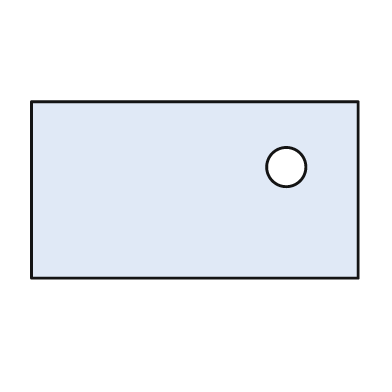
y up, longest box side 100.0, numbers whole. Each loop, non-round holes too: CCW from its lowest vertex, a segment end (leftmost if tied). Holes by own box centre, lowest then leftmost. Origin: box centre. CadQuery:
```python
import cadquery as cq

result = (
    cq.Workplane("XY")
    .moveTo(-50.0, -27.0)
    .lineTo(50.0, -27.0)
    .lineTo(50.0, 27.0)
    .lineTo(-50.0, 27.0)
    .close()
    .moveTo(28.0, 7.0)
    .circle(6.0)
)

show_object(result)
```